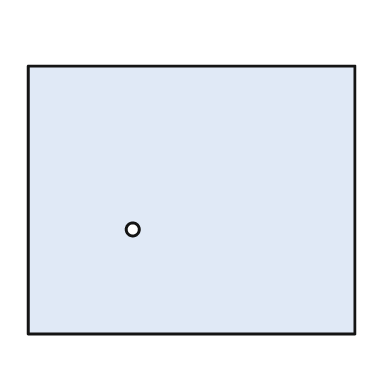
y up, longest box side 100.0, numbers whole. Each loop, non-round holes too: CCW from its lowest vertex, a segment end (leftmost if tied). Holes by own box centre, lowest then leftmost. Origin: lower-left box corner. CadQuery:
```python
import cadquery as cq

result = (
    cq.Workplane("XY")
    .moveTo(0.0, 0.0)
    .lineTo(100.0, 0.0)
    .lineTo(100.0, 82.0)
    .lineTo(0.0, 82.0)
    .close()
    .moveTo(32.0, 32.0)
    .circle(2.0)
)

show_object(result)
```